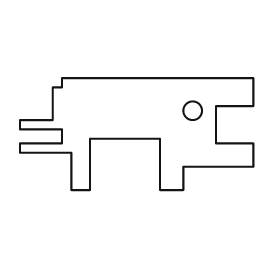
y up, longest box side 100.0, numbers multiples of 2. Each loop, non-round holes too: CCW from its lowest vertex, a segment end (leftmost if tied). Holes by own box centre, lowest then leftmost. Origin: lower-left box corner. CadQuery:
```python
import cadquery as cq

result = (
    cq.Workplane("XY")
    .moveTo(22.0, 0.0)
    .lineTo(30.0, 0.0)
    .lineTo(30.0, 22.0)
    .lineTo(60.0, 22.0)
    .lineTo(60.0, 0.0)
    .lineTo(70.0, 0.0)
    .lineTo(70.0, 10.0)
    .lineTo(100.0, 10.0)
    .lineTo(100.0, 20.0)
    .lineTo(84.0, 20.0)
    .lineTo(84.0, 36.0)
    .lineTo(100.0, 36.0)
    .lineTo(100.0, 48.0)
    .lineTo(18.0, 48.0)
    .lineTo(18.0, 44.0)
    .lineTo(14.0, 44.0)
    .lineTo(14.0, 30.0)
    .lineTo(0.0, 30.0)
    .lineTo(0.0, 26.0)
    .lineTo(18.0, 26.0)
    .lineTo(18.0, 20.0)
    .lineTo(0.0, 20.0)
    .lineTo(0.0, 16.0)
    .lineTo(22.0, 16.0)
    .close()
    .moveTo(74.0, 34.0)
    .circle(4.0)
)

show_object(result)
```